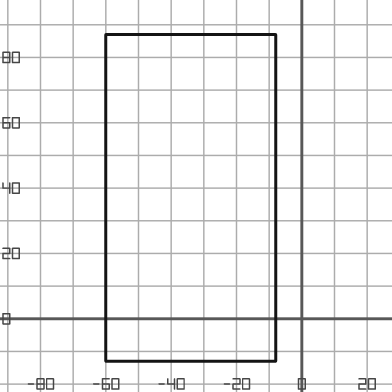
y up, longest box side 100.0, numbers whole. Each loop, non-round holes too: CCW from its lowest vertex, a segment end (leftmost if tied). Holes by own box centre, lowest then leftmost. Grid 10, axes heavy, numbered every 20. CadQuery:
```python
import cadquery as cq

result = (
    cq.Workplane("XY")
    .moveTo(-60.0, -13.0)
    .lineTo(-8.0, -13.0)
    .lineTo(-8.0, 87.0)
    .lineTo(-60.0, 87.0)
    .close()
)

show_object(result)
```